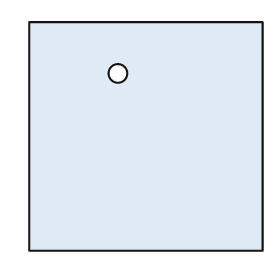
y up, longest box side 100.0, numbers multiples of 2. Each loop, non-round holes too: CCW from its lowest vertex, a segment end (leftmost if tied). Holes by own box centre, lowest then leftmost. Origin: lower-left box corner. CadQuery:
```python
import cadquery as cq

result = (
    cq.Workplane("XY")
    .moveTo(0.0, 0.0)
    .lineTo(100.0, 0.0)
    .lineTo(100.0, 98.0)
    .lineTo(0.0, 98.0)
    .close()
    .moveTo(38.0, 76.0)
    .circle(4.0)
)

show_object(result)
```